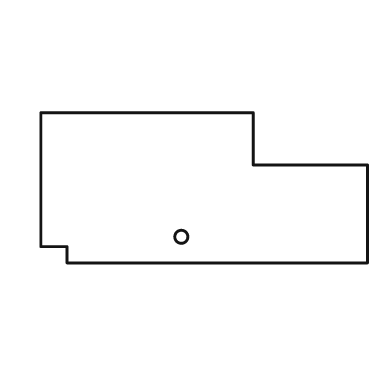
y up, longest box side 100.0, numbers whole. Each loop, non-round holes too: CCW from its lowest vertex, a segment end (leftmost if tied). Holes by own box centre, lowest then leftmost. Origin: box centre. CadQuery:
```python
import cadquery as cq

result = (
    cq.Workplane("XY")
    .moveTo(-42.0, -23.0)
    .lineTo(50.0, -23.0)
    .lineTo(50.0, 7.0)
    .lineTo(15.0, 7.0)
    .lineTo(15.0, 23.0)
    .lineTo(-50.0, 23.0)
    .lineTo(-50.0, -18.0)
    .lineTo(-42.0, -18.0)
    .close()
    .moveTo(-7.0, -15.0)
    .circle(2.0)
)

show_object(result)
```